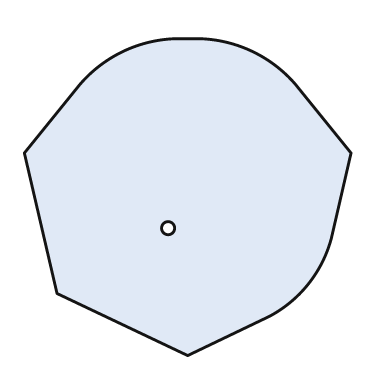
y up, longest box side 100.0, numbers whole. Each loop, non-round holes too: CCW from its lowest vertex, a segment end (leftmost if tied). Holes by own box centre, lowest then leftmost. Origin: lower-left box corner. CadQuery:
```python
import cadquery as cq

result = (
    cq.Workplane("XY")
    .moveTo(50.0, 0.0)
    .lineTo(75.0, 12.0)
    .threePointArc((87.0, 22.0), (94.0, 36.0))
    .lineTo(100.0, 62.0)
    .lineTo(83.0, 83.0)
    .threePointArc((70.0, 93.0), (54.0, 97.0))
    .lineTo(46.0, 97.0)
    .threePointArc((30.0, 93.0), (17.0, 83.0))
    .lineTo(0.0, 62.0)
    .lineTo(10.0, 19.0)
    .close()
    .moveTo(44.0, 39.0)
    .circle(2.0)
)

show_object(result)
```